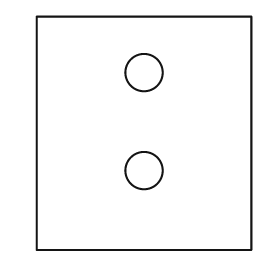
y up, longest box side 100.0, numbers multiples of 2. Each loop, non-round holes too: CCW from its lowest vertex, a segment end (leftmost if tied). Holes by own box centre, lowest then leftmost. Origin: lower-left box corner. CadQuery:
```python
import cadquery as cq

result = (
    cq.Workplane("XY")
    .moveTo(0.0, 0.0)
    .lineTo(92.0, 0.0)
    .lineTo(92.0, 100.0)
    .lineTo(0.0, 100.0)
    .close()
    .moveTo(46.0, 34.0)
    .circle(8.0)
    .moveTo(46.0, 76.0)
    .circle(8.0)
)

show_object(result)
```